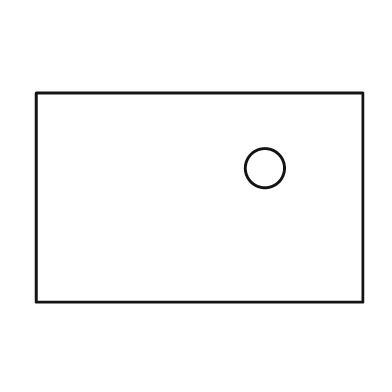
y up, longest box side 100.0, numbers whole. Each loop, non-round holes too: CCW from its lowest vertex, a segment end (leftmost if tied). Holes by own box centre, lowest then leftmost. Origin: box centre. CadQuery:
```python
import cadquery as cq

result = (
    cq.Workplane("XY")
    .moveTo(-50.0, -32.0)
    .lineTo(50.0, -32.0)
    .lineTo(50.0, 32.0)
    .lineTo(-50.0, 32.0)
    .close()
    .moveTo(20.0, 9.0)
    .circle(6.0)
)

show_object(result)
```